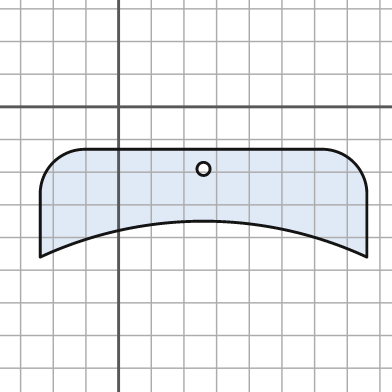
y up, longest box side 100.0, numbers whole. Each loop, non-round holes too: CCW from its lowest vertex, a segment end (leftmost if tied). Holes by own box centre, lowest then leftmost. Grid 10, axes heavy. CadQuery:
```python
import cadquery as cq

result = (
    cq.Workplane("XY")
    .moveTo(-24.0, -46.0)
    .threePointArc((26.0, -35.0), (76.0, -46.0))
    .lineTo(76.0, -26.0)
    .threePointArc((72.0, -17.0), (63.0, -13.0))
    .lineTo(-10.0, -13.0)
    .threePointArc((-20.0, -17.0), (-24.0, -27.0))
    .close()
    .moveTo(26.0, -19.0)
    .circle(2.0)
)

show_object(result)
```